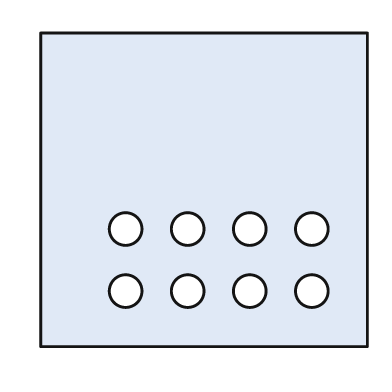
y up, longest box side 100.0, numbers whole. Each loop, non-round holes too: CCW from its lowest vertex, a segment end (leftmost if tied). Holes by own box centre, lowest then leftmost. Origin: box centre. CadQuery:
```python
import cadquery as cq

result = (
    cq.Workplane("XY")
    .moveTo(-50.0, -48.0)
    .lineTo(50.0, -48.0)
    .lineTo(50.0, 48.0)
    .lineTo(-50.0, 48.0)
    .close()
    .moveTo(-24.0, -31.0)
    .circle(5.0)
    .moveTo(-5.0, -31.0)
    .circle(5.0)
    .moveTo(14.0, -31.0)
    .circle(5.0)
    .moveTo(33.0, -31.0)
    .circle(5.0)
    .moveTo(-24.0, -12.0)
    .circle(5.0)
    .moveTo(-5.0, -12.0)
    .circle(5.0)
    .moveTo(14.0, -12.0)
    .circle(5.0)
    .moveTo(33.0, -12.0)
    .circle(5.0)
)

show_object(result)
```